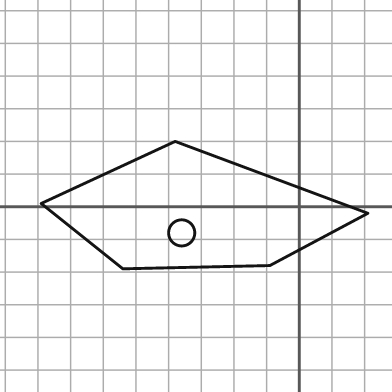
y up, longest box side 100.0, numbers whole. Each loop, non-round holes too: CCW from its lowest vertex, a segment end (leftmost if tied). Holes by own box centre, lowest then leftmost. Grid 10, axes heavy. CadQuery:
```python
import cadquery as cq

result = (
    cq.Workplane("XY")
    .moveTo(-54.0, -19.0)
    .lineTo(-9.0, -18.0)
    .lineTo(21.0, -2.0)
    .lineTo(-38.0, 20.0)
    .lineTo(-79.0, 1.0)
    .close()
    .moveTo(-36.0, -8.0)
    .circle(4.0)
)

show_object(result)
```